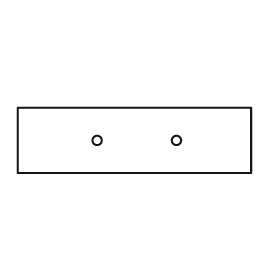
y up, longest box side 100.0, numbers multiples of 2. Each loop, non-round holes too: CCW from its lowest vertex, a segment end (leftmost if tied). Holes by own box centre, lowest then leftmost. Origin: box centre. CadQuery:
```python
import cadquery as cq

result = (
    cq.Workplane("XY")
    .moveTo(-50.0, -14.0)
    .lineTo(50.0, -14.0)
    .lineTo(50.0, 14.0)
    .lineTo(-50.0, 14.0)
    .close()
    .moveTo(-16.0, 0.0)
    .circle(2.0)
    .moveTo(18.0, 0.0)
    .circle(2.0)
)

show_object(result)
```